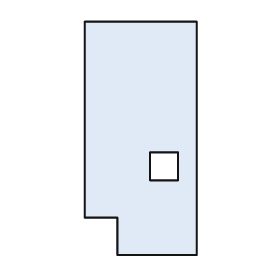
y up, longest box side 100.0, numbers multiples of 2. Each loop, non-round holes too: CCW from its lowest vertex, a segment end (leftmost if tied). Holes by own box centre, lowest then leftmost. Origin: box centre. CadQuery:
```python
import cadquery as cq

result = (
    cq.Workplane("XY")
    .moveTo(-10.0, -50.0)
    .lineTo(24.0, -50.0)
    .lineTo(24.0, 50.0)
    .lineTo(-24.0, 50.0)
    .lineTo(-24.0, -34.0)
    .lineTo(-10.0, -34.0)
    .close()
    .moveTo(4.0, -18.0)
    .lineTo(16.0, -18.0)
    .lineTo(16.0, -6.0)
    .lineTo(4.0, -6.0)
    .close()
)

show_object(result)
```